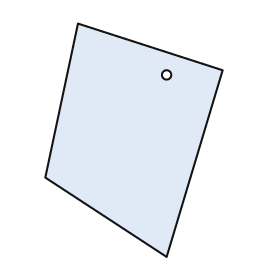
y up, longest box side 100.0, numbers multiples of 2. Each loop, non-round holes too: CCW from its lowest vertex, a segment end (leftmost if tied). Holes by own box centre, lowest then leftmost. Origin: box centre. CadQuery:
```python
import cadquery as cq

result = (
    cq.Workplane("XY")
    .moveTo(14.0, -50.0)
    .lineTo(38.0, 30.0)
    .lineTo(-24.0, 50.0)
    .lineTo(-38.0, -16.0)
    .close()
    .moveTo(14.0, 28.0)
    .circle(2.0)
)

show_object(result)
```